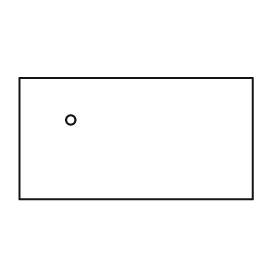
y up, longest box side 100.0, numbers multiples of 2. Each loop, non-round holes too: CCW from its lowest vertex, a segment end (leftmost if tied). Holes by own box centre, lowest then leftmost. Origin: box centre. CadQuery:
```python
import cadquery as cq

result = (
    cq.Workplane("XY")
    .moveTo(-50.0, -26.0)
    .lineTo(50.0, -26.0)
    .lineTo(50.0, 26.0)
    .lineTo(-50.0, 26.0)
    .close()
    .moveTo(-28.0, 8.0)
    .circle(2.0)
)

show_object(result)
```